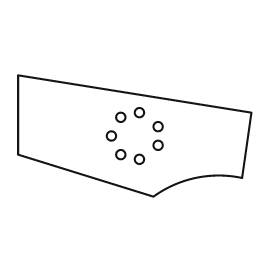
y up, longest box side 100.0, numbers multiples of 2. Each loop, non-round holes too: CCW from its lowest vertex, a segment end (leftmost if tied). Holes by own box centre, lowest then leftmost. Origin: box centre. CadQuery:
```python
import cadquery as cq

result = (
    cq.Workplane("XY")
    .moveTo(8.0, -26.0)
    .threePointArc((26.0, -18.0), (46.0, -18.0))
    .lineTo(50.0, 10.0)
    .lineTo(-50.0, 26.0)
    .lineTo(-50.0, -8.0)
    .close()
    .moveTo(2.0, -10.0)
    .circle(2.0)
    .moveTo(-6.0, -8.0)
    .circle(2.0)
    .moveTo(10.0, -4.0)
    .circle(2.0)
    .moveTo(-10.0, 0.0)
    .circle(2.0)
    .moveTo(10.0, 4.0)
    .circle(2.0)
    .moveTo(-6.0, 8.0)
    .circle(2.0)
    .moveTo(2.0, 10.0)
    .circle(2.0)
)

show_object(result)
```